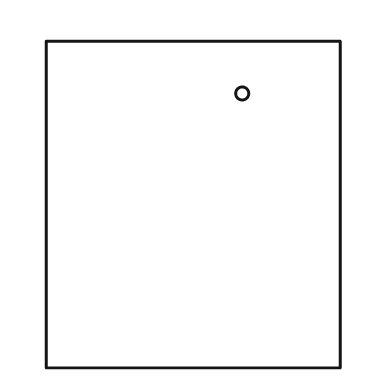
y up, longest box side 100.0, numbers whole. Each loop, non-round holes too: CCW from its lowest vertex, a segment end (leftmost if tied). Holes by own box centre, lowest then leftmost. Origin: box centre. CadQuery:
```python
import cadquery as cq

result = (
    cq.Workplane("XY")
    .moveTo(-45.0, -50.0)
    .lineTo(45.0, -50.0)
    .lineTo(45.0, 50.0)
    .lineTo(-45.0, 50.0)
    .close()
    .moveTo(15.0, 34.0)
    .circle(2.0)
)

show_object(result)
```